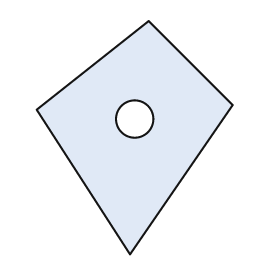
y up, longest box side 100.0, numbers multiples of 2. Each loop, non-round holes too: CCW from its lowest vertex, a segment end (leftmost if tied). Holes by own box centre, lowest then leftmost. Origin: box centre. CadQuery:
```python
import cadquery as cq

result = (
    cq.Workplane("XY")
    .moveTo(-2.0, -50.0)
    .lineTo(42.0, 14.0)
    .lineTo(6.0, 50.0)
    .lineTo(-42.0, 12.0)
    .close()
    .moveTo(0.0, 8.0)
    .circle(8.0)
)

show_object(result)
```